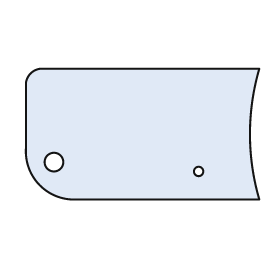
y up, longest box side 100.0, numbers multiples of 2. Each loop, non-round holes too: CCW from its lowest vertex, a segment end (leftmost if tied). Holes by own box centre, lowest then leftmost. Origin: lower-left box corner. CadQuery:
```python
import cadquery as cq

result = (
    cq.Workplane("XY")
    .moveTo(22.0, 0.0)
    .lineTo(100.0, 0.0)
    .threePointArc((96.0, 28.0), (100.0, 56.0))
    .lineTo(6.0, 56.0)
    .threePointArc((2.0, 54.0), (0.0, 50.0))
    .lineTo(0.0, 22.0)
    .threePointArc((6.0, 6.0), (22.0, 0.0))
    .close()
    .moveTo(74.0, 12.0)
    .circle(2.0)
    .moveTo(12.0, 16.0)
    .circle(4.0)
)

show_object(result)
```